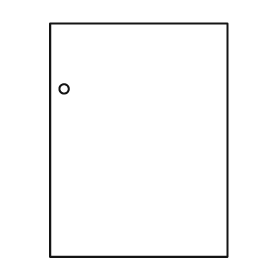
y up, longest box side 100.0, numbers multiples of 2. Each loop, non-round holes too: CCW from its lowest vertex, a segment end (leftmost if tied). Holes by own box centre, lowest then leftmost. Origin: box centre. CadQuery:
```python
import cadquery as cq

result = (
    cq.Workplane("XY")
    .moveTo(-38.0, -50.0)
    .lineTo(38.0, -50.0)
    .lineTo(38.0, 50.0)
    .lineTo(-38.0, 50.0)
    .close()
    .moveTo(-32.0, 22.0)
    .circle(2.0)
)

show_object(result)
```